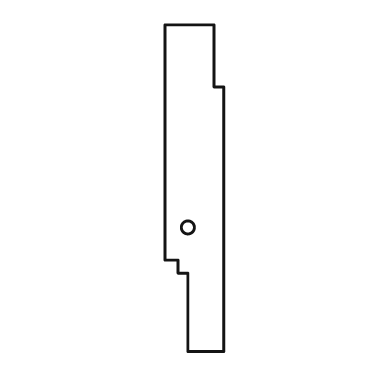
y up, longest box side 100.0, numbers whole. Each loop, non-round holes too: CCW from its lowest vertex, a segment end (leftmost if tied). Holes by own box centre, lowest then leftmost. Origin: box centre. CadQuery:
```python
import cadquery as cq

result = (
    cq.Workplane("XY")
    .moveTo(-2.0, -50.0)
    .lineTo(9.0, -50.0)
    .lineTo(9.0, 31.0)
    .lineTo(6.0, 31.0)
    .lineTo(6.0, 50.0)
    .lineTo(-9.0, 50.0)
    .lineTo(-9.0, -22.0)
    .lineTo(-5.0, -22.0)
    .lineTo(-5.0, -26.0)
    .lineTo(-2.0, -26.0)
    .close()
    .moveTo(-2.0, -12.0)
    .circle(2.0)
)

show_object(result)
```